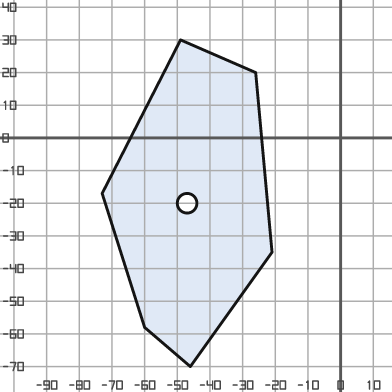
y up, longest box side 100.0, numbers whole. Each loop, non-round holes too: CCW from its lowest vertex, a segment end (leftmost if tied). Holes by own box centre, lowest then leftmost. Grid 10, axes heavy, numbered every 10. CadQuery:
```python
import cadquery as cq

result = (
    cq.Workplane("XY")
    .moveTo(-46.0, -70.0)
    .lineTo(-21.0, -35.0)
    .lineTo(-26.0, 20.0)
    .lineTo(-49.0, 30.0)
    .lineTo(-73.0, -17.0)
    .lineTo(-60.0, -58.0)
    .close()
    .moveTo(-47.0, -20.0)
    .circle(3.0)
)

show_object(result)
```